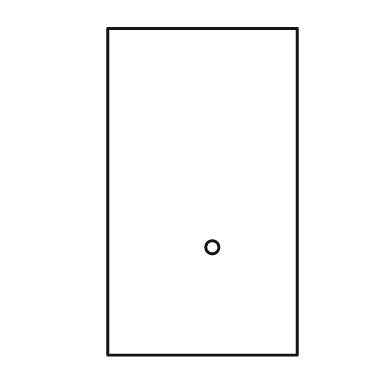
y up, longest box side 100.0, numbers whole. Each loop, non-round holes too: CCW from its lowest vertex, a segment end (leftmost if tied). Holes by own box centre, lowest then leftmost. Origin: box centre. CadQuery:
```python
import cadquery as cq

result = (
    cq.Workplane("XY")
    .moveTo(-29.0, -50.0)
    .lineTo(29.0, -50.0)
    .lineTo(29.0, 50.0)
    .lineTo(-29.0, 50.0)
    .close()
    .moveTo(3.0, -17.0)
    .circle(2.0)
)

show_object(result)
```